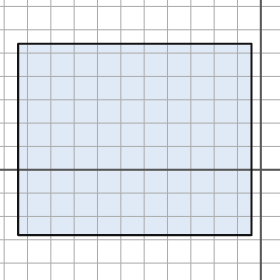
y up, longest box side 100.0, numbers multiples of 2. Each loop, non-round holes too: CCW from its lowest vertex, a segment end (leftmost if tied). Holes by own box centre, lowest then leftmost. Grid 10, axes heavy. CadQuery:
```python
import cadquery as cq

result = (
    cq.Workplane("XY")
    .moveTo(-104.0, -28.0)
    .lineTo(-4.0, -28.0)
    .lineTo(-4.0, 54.0)
    .lineTo(-104.0, 54.0)
    .close()
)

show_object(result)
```